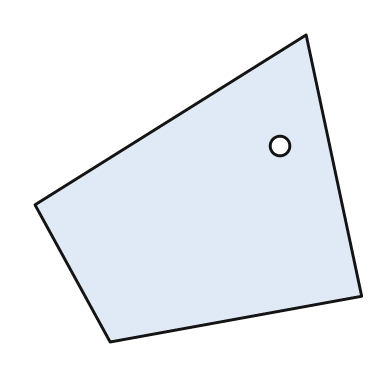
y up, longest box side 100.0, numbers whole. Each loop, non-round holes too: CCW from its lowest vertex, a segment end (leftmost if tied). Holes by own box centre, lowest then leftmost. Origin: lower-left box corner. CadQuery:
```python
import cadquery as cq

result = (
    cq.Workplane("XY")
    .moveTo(23.0, 0.0)
    .lineTo(100.0, 14.0)
    .lineTo(83.0, 94.0)
    .lineTo(0.0, 42.0)
    .close()
    .moveTo(75.0, 60.0)
    .circle(3.0)
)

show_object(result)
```